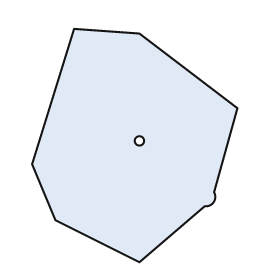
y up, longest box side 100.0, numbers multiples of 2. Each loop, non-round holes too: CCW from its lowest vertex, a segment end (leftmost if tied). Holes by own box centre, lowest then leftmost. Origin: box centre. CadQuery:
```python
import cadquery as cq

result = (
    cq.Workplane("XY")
    .moveTo(2.0, -50.0)
    .lineTo(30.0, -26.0)
    .threePointArc((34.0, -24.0), (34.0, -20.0))
    .lineTo(44.0, 16.0)
    .lineTo(2.0, 48.0)
    .lineTo(-26.0, 50.0)
    .lineTo(-44.0, -8.0)
    .lineTo(-34.0, -32.0)
    .close()
    .moveTo(2.0, 2.0)
    .circle(2.0)
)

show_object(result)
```